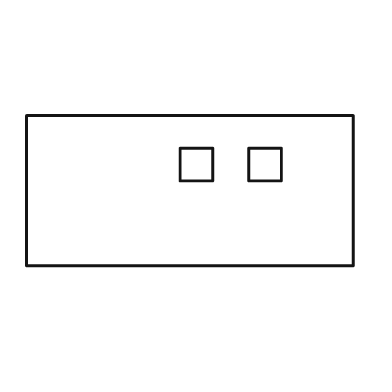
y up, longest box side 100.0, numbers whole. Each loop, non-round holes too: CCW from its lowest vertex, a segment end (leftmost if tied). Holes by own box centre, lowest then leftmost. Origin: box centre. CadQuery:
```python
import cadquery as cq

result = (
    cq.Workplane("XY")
    .moveTo(-50.0, -23.0)
    .lineTo(50.0, -23.0)
    .lineTo(50.0, 23.0)
    .lineTo(-50.0, 23.0)
    .close()
    .moveTo(-3.0, 3.0)
    .lineTo(7.0, 3.0)
    .lineTo(7.0, 13.0)
    .lineTo(-3.0, 13.0)
    .close()
    .moveTo(18.0, 3.0)
    .lineTo(28.0, 3.0)
    .lineTo(28.0, 13.0)
    .lineTo(18.0, 13.0)
    .close()
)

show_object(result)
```